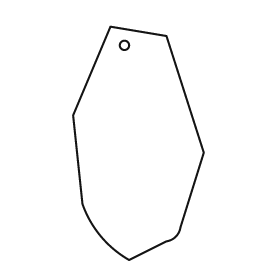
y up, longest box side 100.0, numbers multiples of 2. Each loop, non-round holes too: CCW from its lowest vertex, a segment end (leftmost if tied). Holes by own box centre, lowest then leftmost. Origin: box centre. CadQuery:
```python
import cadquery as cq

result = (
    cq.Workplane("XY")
    .moveTo(-4.0, -50.0)
    .lineTo(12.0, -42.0)
    .threePointArc((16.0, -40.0), (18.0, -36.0))
    .lineTo(28.0, -4.0)
    .lineTo(12.0, 46.0)
    .lineTo(-12.0, 50.0)
    .lineTo(-28.0, 12.0)
    .lineTo(-24.0, -26.0)
    .threePointArc((-16.0, -40.0), (-4.0, -50.0))
    .close()
    .moveTo(-6.0, 42.0)
    .circle(2.0)
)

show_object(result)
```